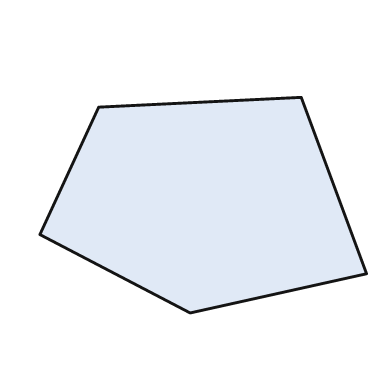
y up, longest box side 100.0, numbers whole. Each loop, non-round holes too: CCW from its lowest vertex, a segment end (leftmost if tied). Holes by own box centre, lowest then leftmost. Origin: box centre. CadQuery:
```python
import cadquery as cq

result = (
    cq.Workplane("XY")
    .moveTo(-4.0, -33.0)
    .lineTo(50.0, -21.0)
    .lineTo(30.0, 33.0)
    .lineTo(-32.0, 30.0)
    .lineTo(-50.0, -9.0)
    .close()
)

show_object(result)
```